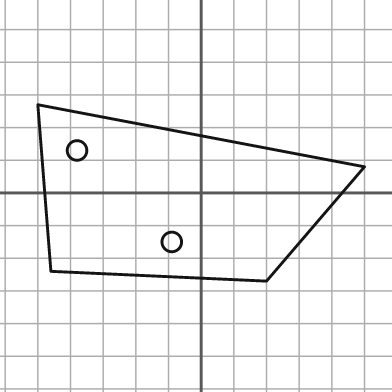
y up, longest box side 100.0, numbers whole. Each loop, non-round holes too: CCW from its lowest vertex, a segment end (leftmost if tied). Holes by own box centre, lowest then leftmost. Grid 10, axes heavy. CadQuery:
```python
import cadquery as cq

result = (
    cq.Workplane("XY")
    .moveTo(20.0, -27.0)
    .lineTo(50.0, 8.0)
    .lineTo(-50.0, 27.0)
    .lineTo(-46.0, -24.0)
    .close()
    .moveTo(-9.0, -15.0)
    .circle(3.0)
    .moveTo(-38.0, 13.0)
    .circle(3.0)
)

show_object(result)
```